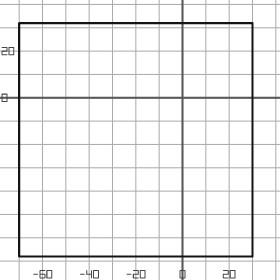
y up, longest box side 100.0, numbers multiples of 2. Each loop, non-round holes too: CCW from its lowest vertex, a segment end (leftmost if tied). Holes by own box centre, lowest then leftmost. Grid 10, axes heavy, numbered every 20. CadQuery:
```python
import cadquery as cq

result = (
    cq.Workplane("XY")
    .moveTo(-70.0, -68.0)
    .lineTo(30.0, -68.0)
    .lineTo(30.0, 32.0)
    .lineTo(-70.0, 32.0)
    .close()
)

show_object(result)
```